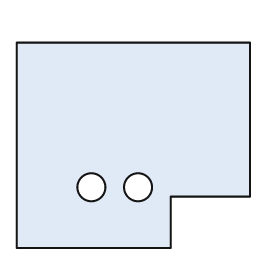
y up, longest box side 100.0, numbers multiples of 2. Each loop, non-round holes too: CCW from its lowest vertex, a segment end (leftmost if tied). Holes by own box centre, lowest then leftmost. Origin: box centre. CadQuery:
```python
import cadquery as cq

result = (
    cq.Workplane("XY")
    .moveTo(-50.0, -44.0)
    .lineTo(16.0, -44.0)
    .lineTo(16.0, -22.0)
    .lineTo(50.0, -22.0)
    .lineTo(50.0, 44.0)
    .lineTo(-50.0, 44.0)
    .close()
    .moveTo(-18.0, -18.0)
    .circle(6.0)
    .moveTo(2.0, -18.0)
    .circle(6.0)
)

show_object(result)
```